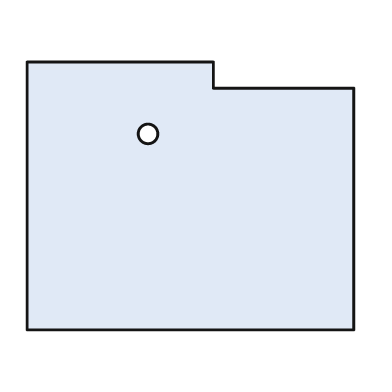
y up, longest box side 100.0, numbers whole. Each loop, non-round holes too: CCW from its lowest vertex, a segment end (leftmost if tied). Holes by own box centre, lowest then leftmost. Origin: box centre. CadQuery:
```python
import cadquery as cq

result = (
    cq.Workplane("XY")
    .moveTo(-50.0, -41.0)
    .lineTo(50.0, -41.0)
    .lineTo(50.0, 33.0)
    .lineTo(7.0, 33.0)
    .lineTo(7.0, 41.0)
    .lineTo(-50.0, 41.0)
    .close()
    .moveTo(-13.0, 19.0)
    .circle(3.0)
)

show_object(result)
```